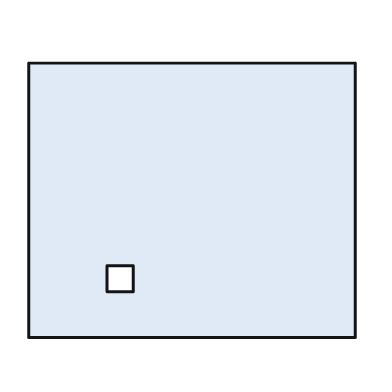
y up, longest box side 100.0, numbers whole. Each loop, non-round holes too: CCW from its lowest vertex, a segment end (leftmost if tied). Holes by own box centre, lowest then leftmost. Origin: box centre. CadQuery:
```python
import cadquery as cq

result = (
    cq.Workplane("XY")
    .moveTo(-50.0, -42.0)
    .lineTo(50.0, -42.0)
    .lineTo(50.0, 42.0)
    .lineTo(-50.0, 42.0)
    .close()
    .moveTo(-26.0, -28.0)
    .lineTo(-18.0, -28.0)
    .lineTo(-18.0, -20.0)
    .lineTo(-26.0, -20.0)
    .close()
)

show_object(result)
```